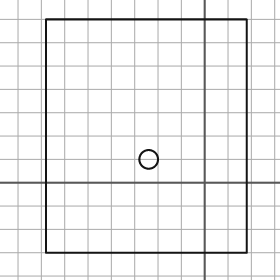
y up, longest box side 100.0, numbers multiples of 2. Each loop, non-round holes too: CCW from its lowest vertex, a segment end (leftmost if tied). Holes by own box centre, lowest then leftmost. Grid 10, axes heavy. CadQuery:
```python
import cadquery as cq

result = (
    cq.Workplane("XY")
    .moveTo(-68.0, -30.0)
    .lineTo(18.0, -30.0)
    .lineTo(18.0, 70.0)
    .lineTo(-68.0, 70.0)
    .close()
    .moveTo(-24.0, 10.0)
    .circle(4.0)
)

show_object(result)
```